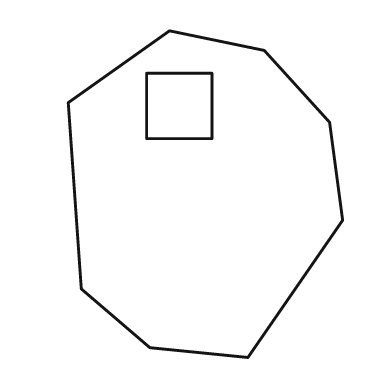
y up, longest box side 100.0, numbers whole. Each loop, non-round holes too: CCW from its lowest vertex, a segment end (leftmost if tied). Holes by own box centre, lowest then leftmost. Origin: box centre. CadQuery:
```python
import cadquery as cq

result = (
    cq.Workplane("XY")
    .moveTo(13.0, -50.0)
    .lineTo(42.0, -8.0)
    .lineTo(38.0, 22.0)
    .lineTo(18.0, 44.0)
    .lineTo(-11.0, 50.0)
    .lineTo(-42.0, 28.0)
    .lineTo(-38.0, -29.0)
    .lineTo(-17.0, -47.0)
    .close()
    .moveTo(-18.0, 17.0)
    .lineTo(2.0, 17.0)
    .lineTo(2.0, 37.0)
    .lineTo(-18.0, 37.0)
    .close()
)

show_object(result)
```